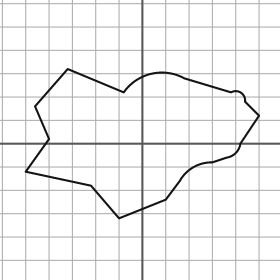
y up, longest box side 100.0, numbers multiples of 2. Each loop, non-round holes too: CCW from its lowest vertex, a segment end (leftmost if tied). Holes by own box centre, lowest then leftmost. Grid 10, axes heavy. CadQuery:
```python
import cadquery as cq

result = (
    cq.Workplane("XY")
    .moveTo(-10.0, -32.0)
    .lineTo(10.0, -24.0)
    .lineTo(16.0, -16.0)
    .threePointArc((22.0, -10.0), (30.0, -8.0))
    .lineTo(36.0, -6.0)
    .threePointArc((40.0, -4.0), (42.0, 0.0))
    .lineTo(50.0, 12.0)
    .lineTo(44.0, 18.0)
    .threePointArc((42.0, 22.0), (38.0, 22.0))
    .lineTo(18.0, 28.0)
    .threePointArc((4.0, 30.0), (-8.0, 22.0))
    .lineTo(-32.0, 32.0)
    .lineTo(-46.0, 16.0)
    .lineTo(-40.0, 2.0)
    .lineTo(-50.0, -12.0)
    .lineTo(-22.0, -18.0)
    .close()
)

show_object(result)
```